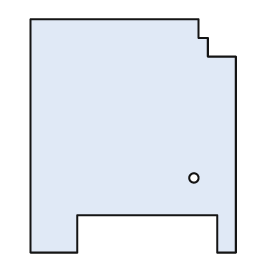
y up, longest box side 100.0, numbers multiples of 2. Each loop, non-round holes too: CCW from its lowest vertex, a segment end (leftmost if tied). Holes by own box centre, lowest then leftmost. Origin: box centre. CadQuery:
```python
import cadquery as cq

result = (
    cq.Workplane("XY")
    .moveTo(-44.0, -50.0)
    .lineTo(-24.0, -50.0)
    .lineTo(-24.0, -34.0)
    .lineTo(36.0, -34.0)
    .lineTo(36.0, -50.0)
    .lineTo(44.0, -50.0)
    .lineTo(44.0, 34.0)
    .lineTo(32.0, 34.0)
    .lineTo(32.0, 42.0)
    .lineTo(28.0, 42.0)
    .lineTo(28.0, 50.0)
    .lineTo(-44.0, 50.0)
    .close()
    .moveTo(26.0, -18.0)
    .circle(2.0)
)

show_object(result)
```